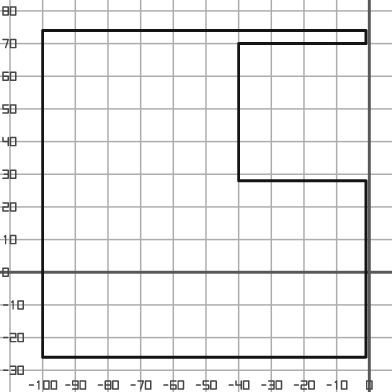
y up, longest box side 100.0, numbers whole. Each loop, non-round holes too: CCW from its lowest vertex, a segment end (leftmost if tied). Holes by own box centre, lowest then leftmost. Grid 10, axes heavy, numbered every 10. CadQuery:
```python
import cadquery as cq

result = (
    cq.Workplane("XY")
    .moveTo(-100.0, -26.0)
    .lineTo(-1.0, -26.0)
    .lineTo(-1.0, 28.0)
    .lineTo(-40.0, 28.0)
    .lineTo(-40.0, 70.0)
    .lineTo(-1.0, 70.0)
    .lineTo(-1.0, 74.0)
    .lineTo(-100.0, 74.0)
    .close()
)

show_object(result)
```